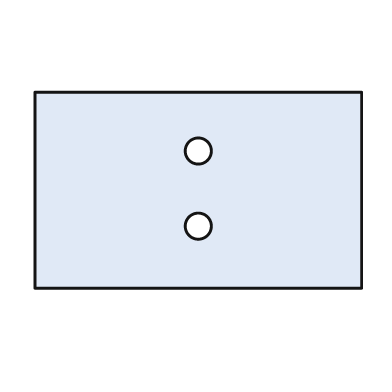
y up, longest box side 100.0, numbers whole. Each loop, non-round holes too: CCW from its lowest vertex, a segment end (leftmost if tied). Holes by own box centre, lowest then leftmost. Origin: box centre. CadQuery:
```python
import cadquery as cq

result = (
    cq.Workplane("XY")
    .moveTo(-50.0, -30.0)
    .lineTo(50.0, -30.0)
    .lineTo(50.0, 30.0)
    .lineTo(-50.0, 30.0)
    .close()
    .moveTo(0.0, -11.0)
    .circle(4.0)
    .moveTo(0.0, 12.0)
    .circle(4.0)
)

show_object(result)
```